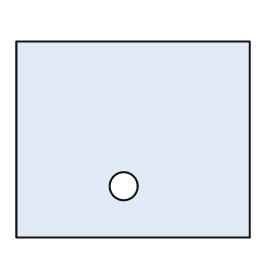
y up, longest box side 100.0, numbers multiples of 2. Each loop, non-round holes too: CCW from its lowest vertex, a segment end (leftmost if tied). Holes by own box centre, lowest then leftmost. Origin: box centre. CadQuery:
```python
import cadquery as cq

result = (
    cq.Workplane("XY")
    .moveTo(-50.0, -42.0)
    .lineTo(50.0, -42.0)
    .lineTo(50.0, 42.0)
    .lineTo(-50.0, 42.0)
    .close()
    .moveTo(-4.0, -20.0)
    .circle(6.0)
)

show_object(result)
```